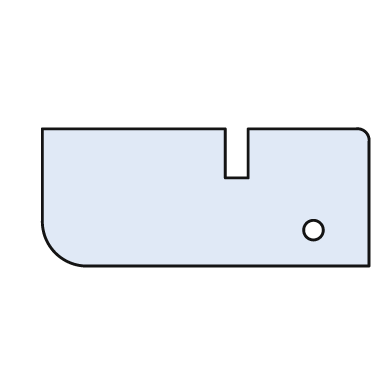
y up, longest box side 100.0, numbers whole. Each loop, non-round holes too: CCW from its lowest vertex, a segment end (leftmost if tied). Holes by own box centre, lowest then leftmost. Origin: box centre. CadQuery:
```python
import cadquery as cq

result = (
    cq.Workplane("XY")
    .moveTo(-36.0, -21.0)
    .lineTo(50.0, -21.0)
    .lineTo(50.0, 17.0)
    .threePointArc((49.0, 20.0), (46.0, 21.0))
    .lineTo(13.0, 21.0)
    .lineTo(13.0, 6.0)
    .lineTo(6.0, 6.0)
    .lineTo(6.0, 21.0)
    .lineTo(-50.0, 21.0)
    .lineTo(-50.0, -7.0)
    .threePointArc((-46.0, -17.0), (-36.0, -21.0))
    .close()
    .moveTo(33.0, -10.0)
    .circle(3.0)
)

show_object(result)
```